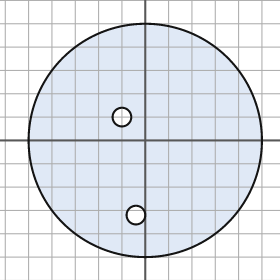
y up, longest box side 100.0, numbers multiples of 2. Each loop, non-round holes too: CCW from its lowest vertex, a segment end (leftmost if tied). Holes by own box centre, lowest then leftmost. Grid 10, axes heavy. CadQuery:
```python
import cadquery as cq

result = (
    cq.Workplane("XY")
    .moveTo(0.0, 0.0)
    .circle(50.0)
    .moveTo(-4.0, -32.0)
    .circle(4.0)
    .moveTo(-10.0, 10.0)
    .circle(4.0)
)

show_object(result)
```